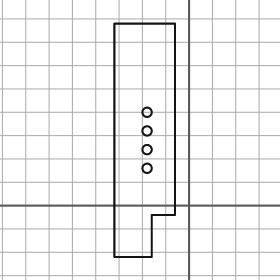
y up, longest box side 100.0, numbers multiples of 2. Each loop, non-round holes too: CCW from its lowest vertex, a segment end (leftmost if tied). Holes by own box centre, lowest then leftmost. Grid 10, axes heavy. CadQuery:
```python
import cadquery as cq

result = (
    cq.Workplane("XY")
    .moveTo(-32.0, -22.0)
    .lineTo(-16.0, -22.0)
    .lineTo(-16.0, -4.0)
    .lineTo(-6.0, -4.0)
    .lineTo(-6.0, 78.0)
    .lineTo(-32.0, 78.0)
    .close()
    .moveTo(-18.0, 16.0)
    .circle(2.0)
    .moveTo(-18.0, 24.0)
    .circle(2.0)
    .moveTo(-18.0, 32.0)
    .circle(2.0)
    .moveTo(-18.0, 40.0)
    .circle(2.0)
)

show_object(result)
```